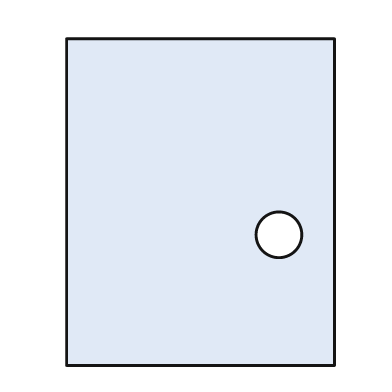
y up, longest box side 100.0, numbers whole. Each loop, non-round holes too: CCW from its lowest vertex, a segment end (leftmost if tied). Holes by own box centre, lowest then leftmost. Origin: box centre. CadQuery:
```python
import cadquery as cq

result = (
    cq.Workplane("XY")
    .moveTo(-41.0, -50.0)
    .lineTo(41.0, -50.0)
    .lineTo(41.0, 50.0)
    .lineTo(-41.0, 50.0)
    .close()
    .moveTo(24.0, -10.0)
    .circle(7.0)
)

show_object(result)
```